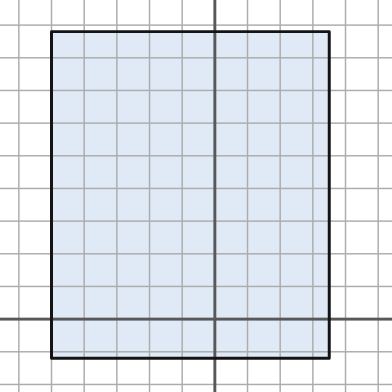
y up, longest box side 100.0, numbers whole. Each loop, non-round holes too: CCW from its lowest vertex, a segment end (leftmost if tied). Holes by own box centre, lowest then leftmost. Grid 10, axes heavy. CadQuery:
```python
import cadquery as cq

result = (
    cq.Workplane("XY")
    .moveTo(-50.0, -12.0)
    .lineTo(35.0, -12.0)
    .lineTo(35.0, 88.0)
    .lineTo(-50.0, 88.0)
    .close()
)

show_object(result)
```